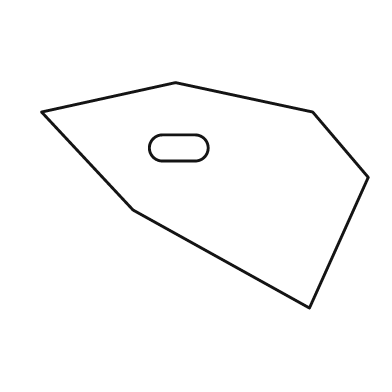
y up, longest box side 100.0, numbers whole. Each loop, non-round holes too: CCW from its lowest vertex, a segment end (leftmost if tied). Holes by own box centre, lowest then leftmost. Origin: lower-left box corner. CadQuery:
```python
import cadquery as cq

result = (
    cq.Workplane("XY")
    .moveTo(82.0, 0.0)
    .lineTo(100.0, 40.0)
    .lineTo(83.0, 60.0)
    .lineTo(41.0, 69.0)
    .lineTo(0.0, 60.0)
    .lineTo(28.0, 30.0)
    .close()
    .moveTo(37.0, 45.0)
    .lineTo(47.0, 45.0)
    .threePointArc((51.0, 49.0), (47.0, 53.0))
    .lineTo(37.0, 53.0)
    .threePointArc((33.0, 49.0), (37.0, 45.0))
    .close()
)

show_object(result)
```